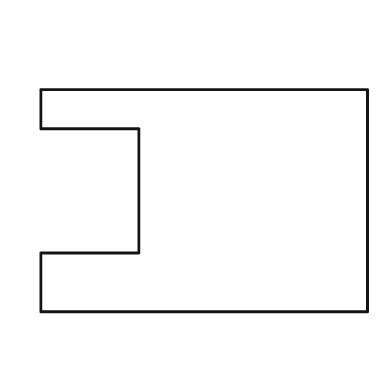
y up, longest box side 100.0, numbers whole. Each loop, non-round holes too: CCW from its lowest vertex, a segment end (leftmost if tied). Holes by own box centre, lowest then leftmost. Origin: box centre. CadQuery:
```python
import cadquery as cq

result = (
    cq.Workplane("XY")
    .moveTo(-50.0, -34.0)
    .lineTo(50.0, -34.0)
    .lineTo(50.0, 34.0)
    .lineTo(-50.0, 34.0)
    .lineTo(-50.0, 22.0)
    .lineTo(-20.0, 22.0)
    .lineTo(-20.0, -16.0)
    .lineTo(-50.0, -16.0)
    .close()
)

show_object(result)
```